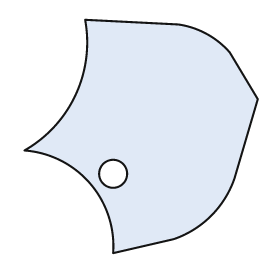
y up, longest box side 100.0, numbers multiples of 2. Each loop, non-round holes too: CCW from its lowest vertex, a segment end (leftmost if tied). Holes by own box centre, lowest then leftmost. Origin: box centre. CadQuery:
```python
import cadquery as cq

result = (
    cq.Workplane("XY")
    .moveTo(-12.0, -50.0)
    .lineTo(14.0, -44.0)
    .threePointArc((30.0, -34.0), (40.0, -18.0))
    .lineTo(50.0, 16.0)
    .lineTo(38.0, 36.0)
    .threePointArc((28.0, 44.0), (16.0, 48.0))
    .lineTo(-24.0, 50.0)
    .threePointArc((-28.0, 18.0), (-50.0, -6.0))
    .threePointArc((-22.0, -20.0), (-12.0, -50.0))
    .close()
    .moveTo(-12.0, -16.0)
    .circle(6.0)
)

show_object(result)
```